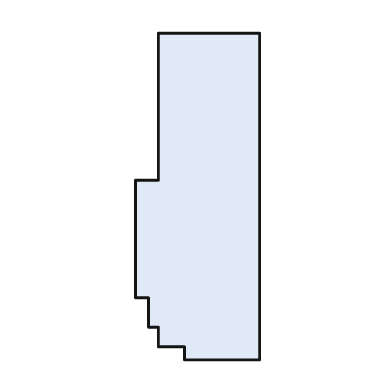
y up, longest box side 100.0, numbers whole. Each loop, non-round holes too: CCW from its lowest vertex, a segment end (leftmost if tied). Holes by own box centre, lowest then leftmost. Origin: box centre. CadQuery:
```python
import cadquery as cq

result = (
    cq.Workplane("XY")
    .moveTo(-4.0, -50.0)
    .lineTo(19.0, -50.0)
    .lineTo(19.0, 50.0)
    .lineTo(-12.0, 50.0)
    .lineTo(-12.0, 5.0)
    .lineTo(-19.0, 5.0)
    .lineTo(-19.0, -31.0)
    .lineTo(-15.0, -31.0)
    .lineTo(-15.0, -40.0)
    .lineTo(-12.0, -40.0)
    .lineTo(-12.0, -46.0)
    .lineTo(-4.0, -46.0)
    .close()
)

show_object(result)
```